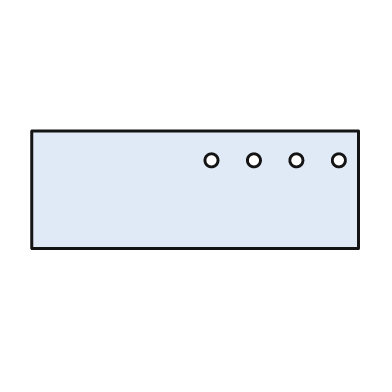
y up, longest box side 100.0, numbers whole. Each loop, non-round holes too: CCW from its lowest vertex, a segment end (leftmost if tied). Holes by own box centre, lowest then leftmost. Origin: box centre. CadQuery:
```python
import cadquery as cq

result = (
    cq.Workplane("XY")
    .moveTo(-50.0, -18.0)
    .lineTo(50.0, -18.0)
    .lineTo(50.0, 18.0)
    .lineTo(-50.0, 18.0)
    .close()
    .moveTo(5.0, 9.0)
    .circle(2.0)
    .moveTo(18.0, 9.0)
    .circle(2.0)
    .moveTo(31.0, 9.0)
    .circle(2.0)
    .moveTo(44.0, 9.0)
    .circle(2.0)
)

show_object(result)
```